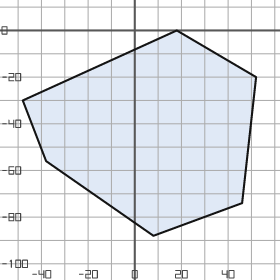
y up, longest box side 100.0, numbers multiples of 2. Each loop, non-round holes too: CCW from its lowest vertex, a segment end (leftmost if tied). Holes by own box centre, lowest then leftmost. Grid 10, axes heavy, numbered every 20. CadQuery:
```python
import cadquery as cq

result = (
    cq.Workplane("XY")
    .moveTo(8.0, -88.0)
    .lineTo(46.0, -74.0)
    .lineTo(52.0, -20.0)
    .lineTo(18.0, 0.0)
    .lineTo(-48.0, -30.0)
    .lineTo(-38.0, -56.0)
    .close()
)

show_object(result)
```